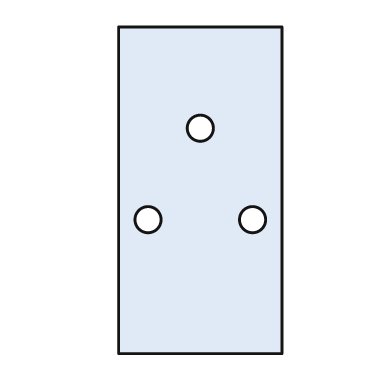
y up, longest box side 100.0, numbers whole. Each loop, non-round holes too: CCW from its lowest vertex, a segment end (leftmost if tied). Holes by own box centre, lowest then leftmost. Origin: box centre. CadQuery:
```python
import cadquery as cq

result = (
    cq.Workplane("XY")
    .moveTo(-25.0, -50.0)
    .lineTo(25.0, -50.0)
    .lineTo(25.0, 50.0)
    .lineTo(-25.0, 50.0)
    .close()
    .moveTo(-16.0, -9.0)
    .circle(4.0)
    .moveTo(16.0, -9.0)
    .circle(4.0)
    .moveTo(0.0, 19.0)
    .circle(4.0)
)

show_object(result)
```